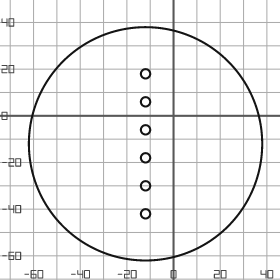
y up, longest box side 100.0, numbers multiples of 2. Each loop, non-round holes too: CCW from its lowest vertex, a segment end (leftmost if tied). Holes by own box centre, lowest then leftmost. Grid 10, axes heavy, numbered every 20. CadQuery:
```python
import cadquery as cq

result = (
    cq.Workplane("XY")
    .moveTo(-12.0, -12.0)
    .circle(50.0)
    .moveTo(-12.0, -42.0)
    .circle(2.0)
    .moveTo(-12.0, -30.0)
    .circle(2.0)
    .moveTo(-12.0, -18.0)
    .circle(2.0)
    .moveTo(-12.0, -6.0)
    .circle(2.0)
    .moveTo(-12.0, 6.0)
    .circle(2.0)
    .moveTo(-12.0, 18.0)
    .circle(2.0)
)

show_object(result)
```